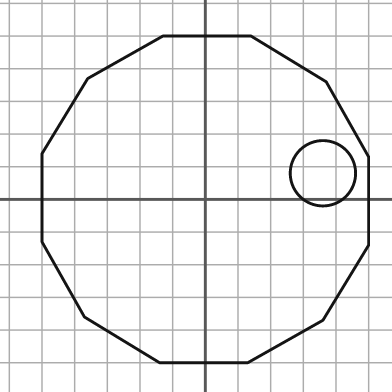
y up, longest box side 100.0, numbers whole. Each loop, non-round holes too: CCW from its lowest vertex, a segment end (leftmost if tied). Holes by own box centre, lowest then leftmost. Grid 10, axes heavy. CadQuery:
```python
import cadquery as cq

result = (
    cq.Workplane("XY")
    .moveTo(-14.0, -50.0)
    .lineTo(13.0, -50.0)
    .lineTo(36.0, -37.0)
    .lineTo(50.0, -14.0)
    .lineTo(50.0, 13.0)
    .lineTo(37.0, 36.0)
    .lineTo(14.0, 50.0)
    .lineTo(-13.0, 50.0)
    .lineTo(-36.0, 37.0)
    .lineTo(-50.0, 14.0)
    .lineTo(-50.0, -13.0)
    .lineTo(-37.0, -36.0)
    .close()
    .moveTo(36.0, 8.0)
    .circle(10.0)
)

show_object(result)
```